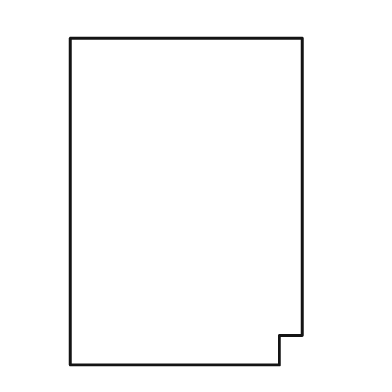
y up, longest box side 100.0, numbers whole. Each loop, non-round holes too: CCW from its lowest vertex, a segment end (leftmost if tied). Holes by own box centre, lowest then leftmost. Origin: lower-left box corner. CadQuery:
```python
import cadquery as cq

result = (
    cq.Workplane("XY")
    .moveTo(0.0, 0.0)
    .lineTo(64.0, 0.0)
    .lineTo(64.0, 9.0)
    .lineTo(71.0, 9.0)
    .lineTo(71.0, 100.0)
    .lineTo(0.0, 100.0)
    .close()
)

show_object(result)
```